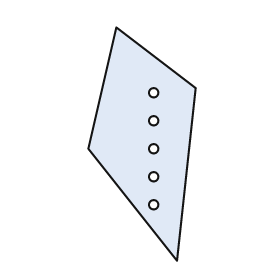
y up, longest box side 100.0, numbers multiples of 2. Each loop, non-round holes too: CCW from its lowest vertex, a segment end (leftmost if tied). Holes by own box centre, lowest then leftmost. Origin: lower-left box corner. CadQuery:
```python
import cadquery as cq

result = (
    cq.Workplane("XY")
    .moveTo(38.0, 0.0)
    .lineTo(46.0, 74.0)
    .lineTo(12.0, 100.0)
    .lineTo(0.0, 48.0)
    .close()
    .moveTo(28.0, 24.0)
    .circle(2.0)
    .moveTo(28.0, 36.0)
    .circle(2.0)
    .moveTo(28.0, 48.0)
    .circle(2.0)
    .moveTo(28.0, 60.0)
    .circle(2.0)
    .moveTo(28.0, 72.0)
    .circle(2.0)
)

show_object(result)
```